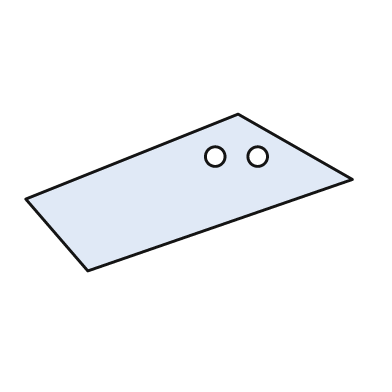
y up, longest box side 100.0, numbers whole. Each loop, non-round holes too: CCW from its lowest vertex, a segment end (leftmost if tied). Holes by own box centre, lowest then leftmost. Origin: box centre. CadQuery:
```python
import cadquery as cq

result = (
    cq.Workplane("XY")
    .moveTo(-31.0, -24.0)
    .lineTo(50.0, 4.0)
    .lineTo(15.0, 24.0)
    .lineTo(-50.0, -2.0)
    .close()
    .moveTo(8.0, 11.0)
    .circle(3.0)
    .moveTo(21.0, 11.0)
    .circle(3.0)
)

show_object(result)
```